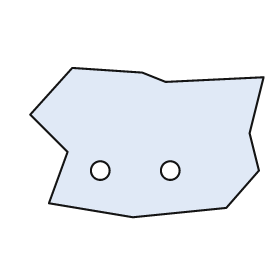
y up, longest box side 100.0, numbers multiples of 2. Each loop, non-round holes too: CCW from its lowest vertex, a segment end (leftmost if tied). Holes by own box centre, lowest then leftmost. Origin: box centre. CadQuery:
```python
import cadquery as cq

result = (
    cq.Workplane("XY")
    .moveTo(-6.0, -32.0)
    .lineTo(34.0, -28.0)
    .lineTo(48.0, -12.0)
    .lineTo(44.0, 4.0)
    .lineTo(50.0, 28.0)
    .lineTo(8.0, 26.0)
    .lineTo(-2.0, 30.0)
    .lineTo(-32.0, 32.0)
    .lineTo(-50.0, 12.0)
    .lineTo(-34.0, -4.0)
    .lineTo(-42.0, -26.0)
    .close()
    .moveTo(-20.0, -12.0)
    .circle(4.0)
    .moveTo(10.0, -12.0)
    .circle(4.0)
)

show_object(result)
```